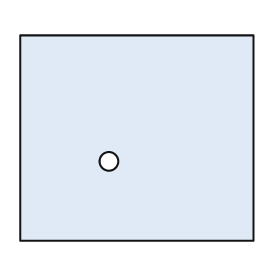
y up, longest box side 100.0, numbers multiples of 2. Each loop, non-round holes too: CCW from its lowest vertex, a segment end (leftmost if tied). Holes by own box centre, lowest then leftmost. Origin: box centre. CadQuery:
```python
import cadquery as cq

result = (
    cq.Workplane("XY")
    .moveTo(-50.0, -44.0)
    .lineTo(50.0, -44.0)
    .lineTo(50.0, 44.0)
    .lineTo(-50.0, 44.0)
    .close()
    .moveTo(-12.0, -10.0)
    .circle(4.0)
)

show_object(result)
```